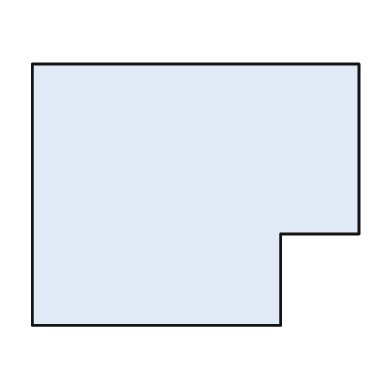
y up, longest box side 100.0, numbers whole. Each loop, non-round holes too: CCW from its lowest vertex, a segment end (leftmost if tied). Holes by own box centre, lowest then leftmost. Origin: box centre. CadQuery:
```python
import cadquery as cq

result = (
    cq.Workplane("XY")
    .moveTo(-50.0, -40.0)
    .lineTo(26.0, -40.0)
    .lineTo(26.0, -12.0)
    .lineTo(50.0, -12.0)
    .lineTo(50.0, 40.0)
    .lineTo(-50.0, 40.0)
    .close()
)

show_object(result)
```